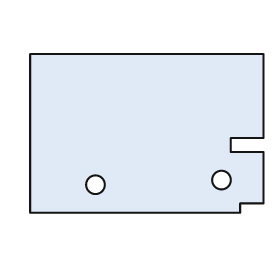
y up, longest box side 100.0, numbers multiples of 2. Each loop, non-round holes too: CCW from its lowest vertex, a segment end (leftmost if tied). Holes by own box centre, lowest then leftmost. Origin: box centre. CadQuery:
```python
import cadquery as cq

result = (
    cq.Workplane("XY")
    .moveTo(-50.0, -34.0)
    .lineTo(40.0, -34.0)
    .lineTo(40.0, -30.0)
    .lineTo(50.0, -30.0)
    .lineTo(50.0, -8.0)
    .lineTo(36.0, -8.0)
    .lineTo(36.0, -2.0)
    .lineTo(50.0, -2.0)
    .lineTo(50.0, 34.0)
    .lineTo(-50.0, 34.0)
    .close()
    .moveTo(-22.0, -22.0)
    .circle(4.0)
    .moveTo(32.0, -20.0)
    .circle(4.0)
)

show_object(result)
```